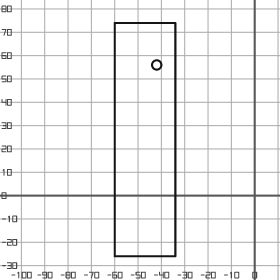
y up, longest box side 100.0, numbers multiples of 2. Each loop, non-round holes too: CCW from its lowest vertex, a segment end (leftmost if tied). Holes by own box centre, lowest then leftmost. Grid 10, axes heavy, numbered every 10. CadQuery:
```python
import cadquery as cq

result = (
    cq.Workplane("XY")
    .moveTo(-60.0, -26.0)
    .lineTo(-34.0, -26.0)
    .lineTo(-34.0, 74.0)
    .lineTo(-60.0, 74.0)
    .close()
    .moveTo(-42.0, 56.0)
    .circle(2.0)
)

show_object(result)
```